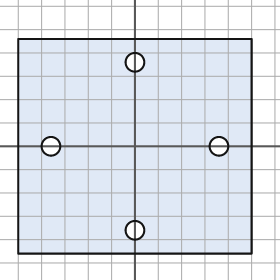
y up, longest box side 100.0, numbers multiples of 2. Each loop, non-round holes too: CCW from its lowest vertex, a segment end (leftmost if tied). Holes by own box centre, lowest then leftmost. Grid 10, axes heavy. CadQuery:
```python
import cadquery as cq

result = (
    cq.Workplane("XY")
    .moveTo(-50.0, -46.0)
    .lineTo(50.0, -46.0)
    .lineTo(50.0, 46.0)
    .lineTo(-50.0, 46.0)
    .close()
    .moveTo(0.0, -36.0)
    .circle(4.0)
    .moveTo(-36.0, 0.0)
    .circle(4.0)
    .moveTo(36.0, 0.0)
    .circle(4.0)
    .moveTo(0.0, 36.0)
    .circle(4.0)
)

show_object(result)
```